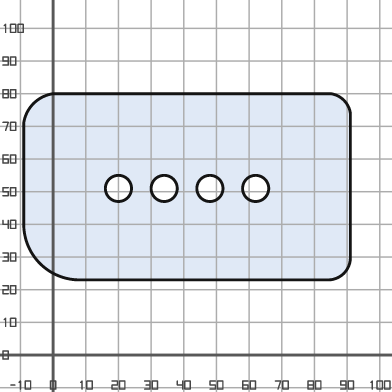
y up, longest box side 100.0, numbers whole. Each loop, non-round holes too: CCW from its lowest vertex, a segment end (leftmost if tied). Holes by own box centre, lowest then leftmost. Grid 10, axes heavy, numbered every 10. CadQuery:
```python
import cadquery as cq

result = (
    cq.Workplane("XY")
    .moveTo(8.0, 23.0)
    .lineTo(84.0, 23.0)
    .threePointArc((89.0, 25.0), (91.0, 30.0))
    .lineTo(91.0, 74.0)
    .threePointArc((89.0, 78.0), (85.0, 80.0))
    .lineTo(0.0, 80.0)
    .threePointArc((-6.0, 77.0), (-9.0, 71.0))
    .lineTo(-9.0, 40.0)
    .threePointArc((-4.0, 28.0), (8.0, 23.0))
    .close()
    .moveTo(20.0, 51.0)
    .circle(4.0)
    .moveTo(34.0, 51.0)
    .circle(4.0)
    .moveTo(48.0, 51.0)
    .circle(4.0)
    .moveTo(62.0, 51.0)
    .circle(4.0)
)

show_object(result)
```